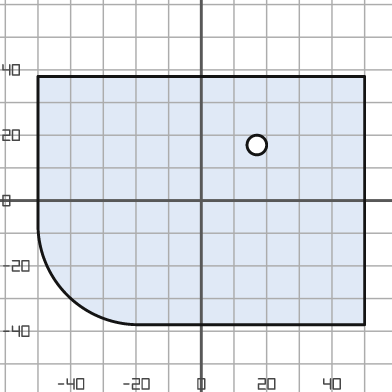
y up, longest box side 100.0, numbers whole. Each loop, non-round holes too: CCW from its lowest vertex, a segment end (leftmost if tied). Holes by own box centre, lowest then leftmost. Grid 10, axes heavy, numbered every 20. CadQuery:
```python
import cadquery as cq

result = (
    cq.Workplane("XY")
    .moveTo(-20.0, -38.0)
    .lineTo(50.0, -38.0)
    .lineTo(50.0, 38.0)
    .lineTo(-50.0, 38.0)
    .lineTo(-50.0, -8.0)
    .threePointArc((-41.0, -29.0), (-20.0, -38.0))
    .close()
    .moveTo(17.0, 17.0)
    .circle(3.0)
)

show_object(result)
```